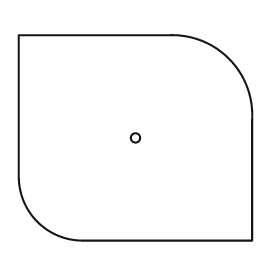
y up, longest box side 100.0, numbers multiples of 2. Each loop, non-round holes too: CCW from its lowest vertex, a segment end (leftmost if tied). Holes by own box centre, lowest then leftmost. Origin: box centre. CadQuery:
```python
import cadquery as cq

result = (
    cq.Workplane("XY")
    .moveTo(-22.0, -44.0)
    .lineTo(50.0, -44.0)
    .lineTo(50.0, 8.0)
    .threePointArc((40.0, 34.0), (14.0, 44.0))
    .lineTo(-50.0, 44.0)
    .lineTo(-50.0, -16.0)
    .threePointArc((-42.0, -36.0), (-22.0, -44.0))
    .close()
    .moveTo(0.0, 0.0)
    .circle(2.0)
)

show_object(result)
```